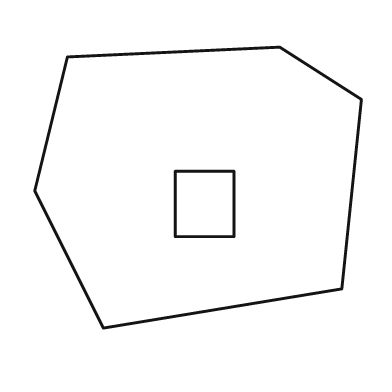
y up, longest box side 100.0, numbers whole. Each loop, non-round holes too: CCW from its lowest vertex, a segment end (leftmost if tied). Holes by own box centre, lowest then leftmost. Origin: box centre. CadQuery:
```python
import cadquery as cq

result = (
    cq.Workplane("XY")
    .moveTo(-29.0, -43.0)
    .lineTo(44.0, -31.0)
    .lineTo(50.0, 27.0)
    .lineTo(25.0, 43.0)
    .lineTo(-40.0, 40.0)
    .lineTo(-50.0, -1.0)
    .close()
    .moveTo(-7.0, -15.0)
    .lineTo(11.0, -15.0)
    .lineTo(11.0, 5.0)
    .lineTo(-7.0, 5.0)
    .close()
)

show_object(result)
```